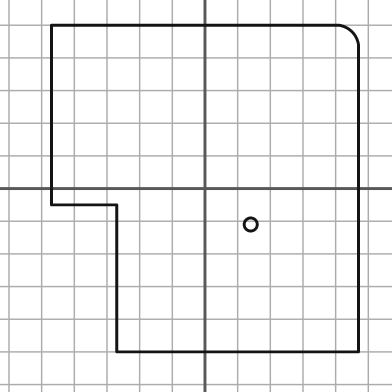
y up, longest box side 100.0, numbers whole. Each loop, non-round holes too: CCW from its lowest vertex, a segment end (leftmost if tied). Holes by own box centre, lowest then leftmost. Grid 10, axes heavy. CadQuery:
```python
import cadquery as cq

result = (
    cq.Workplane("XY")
    .moveTo(-27.0, -50.0)
    .lineTo(47.0, -50.0)
    .lineTo(47.0, 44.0)
    .threePointArc((45.0, 48.0), (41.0, 50.0))
    .lineTo(-47.0, 50.0)
    .lineTo(-47.0, -5.0)
    .lineTo(-27.0, -5.0)
    .close()
    .moveTo(14.0, -11.0)
    .circle(2.0)
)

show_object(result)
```